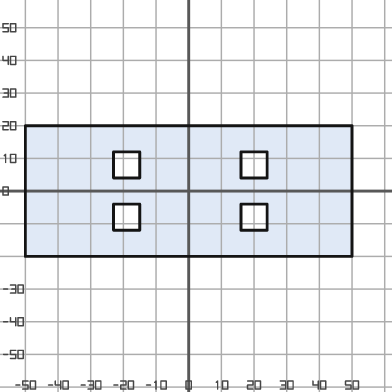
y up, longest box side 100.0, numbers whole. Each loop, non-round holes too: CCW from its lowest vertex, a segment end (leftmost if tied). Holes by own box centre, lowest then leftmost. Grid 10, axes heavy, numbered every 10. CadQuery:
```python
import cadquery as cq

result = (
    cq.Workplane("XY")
    .moveTo(-50.0, -20.0)
    .lineTo(50.0, -20.0)
    .lineTo(50.0, 20.0)
    .lineTo(-50.0, 20.0)
    .close()
    .moveTo(-23.0, -12.0)
    .lineTo(-15.0, -12.0)
    .lineTo(-15.0, -4.0)
    .lineTo(-23.0, -4.0)
    .close()
    .moveTo(16.0, -12.0)
    .lineTo(24.0, -12.0)
    .lineTo(24.0, -4.0)
    .lineTo(16.0, -4.0)
    .close()
    .moveTo(-23.0, 4.0)
    .lineTo(-15.0, 4.0)
    .lineTo(-15.0, 12.0)
    .lineTo(-23.0, 12.0)
    .close()
    .moveTo(16.0, 4.0)
    .lineTo(24.0, 4.0)
    .lineTo(24.0, 12.0)
    .lineTo(16.0, 12.0)
    .close()
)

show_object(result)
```